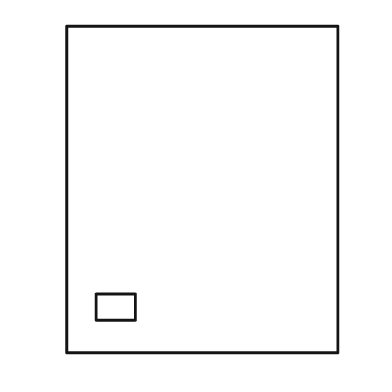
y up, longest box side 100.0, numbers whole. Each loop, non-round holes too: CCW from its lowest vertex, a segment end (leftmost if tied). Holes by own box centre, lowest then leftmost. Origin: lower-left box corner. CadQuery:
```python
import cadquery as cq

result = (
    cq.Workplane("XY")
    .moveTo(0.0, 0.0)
    .lineTo(83.0, 0.0)
    .lineTo(83.0, 100.0)
    .lineTo(0.0, 100.0)
    .close()
    .moveTo(9.0, 10.0)
    .lineTo(21.0, 10.0)
    .lineTo(21.0, 18.0)
    .lineTo(9.0, 18.0)
    .close()
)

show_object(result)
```